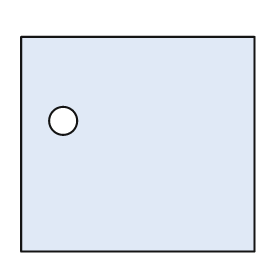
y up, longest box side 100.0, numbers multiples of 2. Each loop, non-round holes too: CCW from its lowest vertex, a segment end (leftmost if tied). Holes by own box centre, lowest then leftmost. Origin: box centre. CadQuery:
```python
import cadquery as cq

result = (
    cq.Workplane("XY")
    .moveTo(-50.0, -46.0)
    .lineTo(50.0, -46.0)
    .lineTo(50.0, 46.0)
    .lineTo(-50.0, 46.0)
    .close()
    .moveTo(-32.0, 10.0)
    .circle(6.0)
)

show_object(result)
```